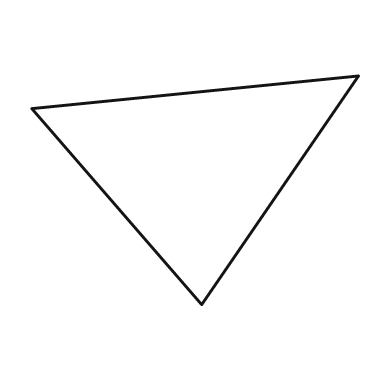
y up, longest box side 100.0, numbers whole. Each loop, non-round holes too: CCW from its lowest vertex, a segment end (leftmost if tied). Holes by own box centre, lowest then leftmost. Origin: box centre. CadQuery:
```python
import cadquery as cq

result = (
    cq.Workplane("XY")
    .moveTo(2.0, -35.0)
    .lineTo(50.0, 35.0)
    .lineTo(-50.0, 25.0)
    .close()
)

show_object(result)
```